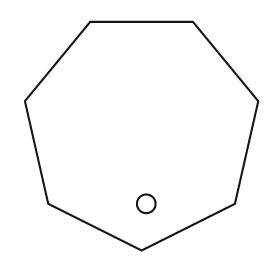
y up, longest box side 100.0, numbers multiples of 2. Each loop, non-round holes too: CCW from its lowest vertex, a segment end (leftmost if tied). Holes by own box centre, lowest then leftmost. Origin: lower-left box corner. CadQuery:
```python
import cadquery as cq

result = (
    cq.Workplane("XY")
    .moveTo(50.0, 0.0)
    .lineTo(90.0, 20.0)
    .lineTo(100.0, 64.0)
    .lineTo(72.0, 98.0)
    .lineTo(28.0, 98.0)
    .lineTo(0.0, 64.0)
    .lineTo(10.0, 20.0)
    .close()
    .moveTo(52.0, 20.0)
    .circle(4.0)
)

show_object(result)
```